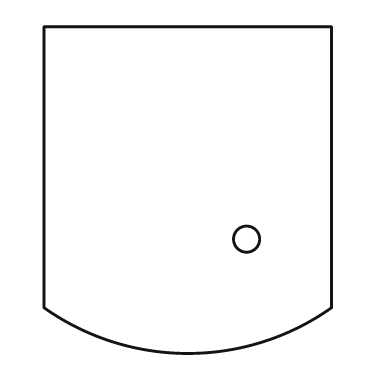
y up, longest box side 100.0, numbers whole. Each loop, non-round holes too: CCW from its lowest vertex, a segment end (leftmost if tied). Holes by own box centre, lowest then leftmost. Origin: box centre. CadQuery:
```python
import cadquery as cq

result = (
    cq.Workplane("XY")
    .moveTo(-44.0, -36.0)
    .threePointArc((0.0, -50.0), (44.0, -36.0))
    .lineTo(44.0, 50.0)
    .lineTo(-44.0, 50.0)
    .close()
    .moveTo(18.0, -15.0)
    .circle(4.0)
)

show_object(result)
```